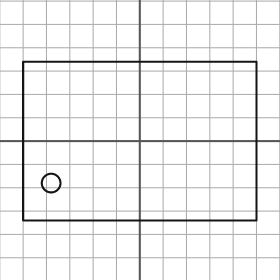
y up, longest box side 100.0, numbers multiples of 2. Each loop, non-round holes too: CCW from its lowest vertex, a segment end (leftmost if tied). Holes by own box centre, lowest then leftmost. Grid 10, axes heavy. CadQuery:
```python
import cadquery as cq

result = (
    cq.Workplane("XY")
    .moveTo(-50.0, -34.0)
    .lineTo(50.0, -34.0)
    .lineTo(50.0, 34.0)
    .lineTo(-50.0, 34.0)
    .close()
    .moveTo(-38.0, -18.0)
    .circle(4.0)
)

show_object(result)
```